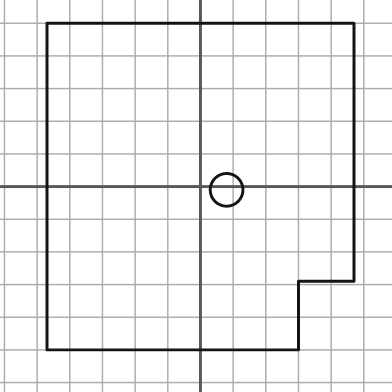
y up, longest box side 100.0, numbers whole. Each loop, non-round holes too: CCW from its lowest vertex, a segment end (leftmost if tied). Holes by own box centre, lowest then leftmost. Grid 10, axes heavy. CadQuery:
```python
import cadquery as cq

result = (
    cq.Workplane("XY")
    .moveTo(-47.0, -50.0)
    .lineTo(30.0, -50.0)
    .lineTo(30.0, -29.0)
    .lineTo(47.0, -29.0)
    .lineTo(47.0, 50.0)
    .lineTo(-47.0, 50.0)
    .close()
    .moveTo(8.0, -1.0)
    .circle(5.0)
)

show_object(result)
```